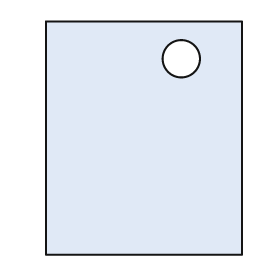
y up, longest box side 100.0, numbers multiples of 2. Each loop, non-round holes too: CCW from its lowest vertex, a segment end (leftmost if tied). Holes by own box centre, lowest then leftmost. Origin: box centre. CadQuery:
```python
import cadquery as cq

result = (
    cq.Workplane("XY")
    .moveTo(-42.0, -50.0)
    .lineTo(42.0, -50.0)
    .lineTo(42.0, 50.0)
    .lineTo(-42.0, 50.0)
    .close()
    .moveTo(16.0, 34.0)
    .circle(8.0)
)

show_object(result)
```